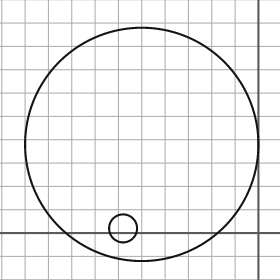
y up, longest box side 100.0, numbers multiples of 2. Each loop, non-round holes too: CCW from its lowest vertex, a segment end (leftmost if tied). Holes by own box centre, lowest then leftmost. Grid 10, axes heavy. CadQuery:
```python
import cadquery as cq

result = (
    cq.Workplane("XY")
    .moveTo(-50.0, 38.0)
    .circle(50.0)
    .moveTo(-58.0, 2.0)
    .circle(6.0)
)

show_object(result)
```